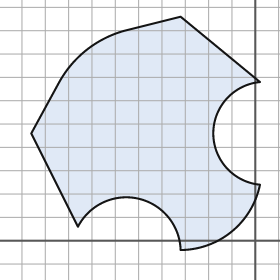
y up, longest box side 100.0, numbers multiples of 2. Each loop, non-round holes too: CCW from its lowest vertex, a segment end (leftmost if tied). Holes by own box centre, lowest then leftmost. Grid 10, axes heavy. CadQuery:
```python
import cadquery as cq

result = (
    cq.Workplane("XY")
    .moveTo(-32.0, -4.0)
    .threePointArc((-10.0, 4.0), (2.0, 24.0))
    .threePointArc((-18.0, 46.0), (2.0, 68.0))
    .lineTo(-32.0, 96.0)
    .lineTo(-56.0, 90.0)
    .threePointArc((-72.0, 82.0), (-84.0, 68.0))
    .lineTo(-96.0, 46.0)
    .lineTo(-76.0, 6.0)
    .threePointArc((-50.0, 18.0), (-32.0, -4.0))
    .close()
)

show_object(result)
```